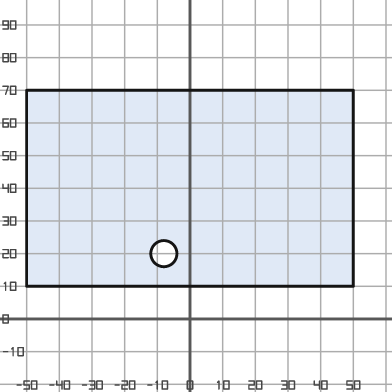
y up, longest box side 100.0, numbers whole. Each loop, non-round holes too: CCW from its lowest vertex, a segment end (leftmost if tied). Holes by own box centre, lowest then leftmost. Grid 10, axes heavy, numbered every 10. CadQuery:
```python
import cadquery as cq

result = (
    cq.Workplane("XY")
    .moveTo(-50.0, 10.0)
    .lineTo(50.0, 10.0)
    .lineTo(50.0, 70.0)
    .lineTo(-50.0, 70.0)
    .close()
    .moveTo(-8.0, 20.0)
    .circle(4.0)
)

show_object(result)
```